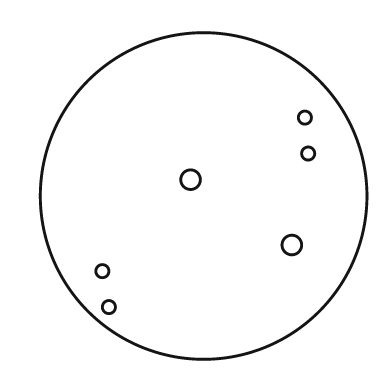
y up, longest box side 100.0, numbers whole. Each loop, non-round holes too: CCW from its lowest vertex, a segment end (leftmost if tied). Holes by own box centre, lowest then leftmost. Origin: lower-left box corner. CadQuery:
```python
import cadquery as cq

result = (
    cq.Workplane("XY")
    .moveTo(50.0, 50.0)
    .circle(50.0)
    .moveTo(21.0, 16.0)
    .circle(2.0)
    .moveTo(19.0, 27.0)
    .circle(2.0)
    .moveTo(77.0, 35.0)
    .circle(3.0)
    .moveTo(46.0, 55.0)
    .circle(3.0)
    .moveTo(82.0, 63.0)
    .circle(2.0)
    .moveTo(81.0, 74.0)
    .circle(2.0)
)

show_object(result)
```